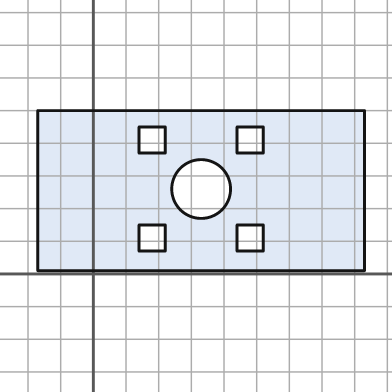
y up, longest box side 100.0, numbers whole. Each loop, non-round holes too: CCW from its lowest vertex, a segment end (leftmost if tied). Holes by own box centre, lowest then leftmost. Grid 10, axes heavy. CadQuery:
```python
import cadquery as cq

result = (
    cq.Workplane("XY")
    .moveTo(-17.0, 1.0)
    .lineTo(83.0, 1.0)
    .lineTo(83.0, 50.0)
    .lineTo(-17.0, 50.0)
    .close()
    .moveTo(14.0, 7.0)
    .lineTo(22.0, 7.0)
    .lineTo(22.0, 15.0)
    .lineTo(14.0, 15.0)
    .close()
    .moveTo(44.0, 7.0)
    .lineTo(52.0, 7.0)
    .lineTo(52.0, 15.0)
    .lineTo(44.0, 15.0)
    .close()
    .moveTo(33.0, 26.0)
    .circle(9.0)
    .moveTo(14.0, 37.0)
    .lineTo(22.0, 37.0)
    .lineTo(22.0, 45.0)
    .lineTo(14.0, 45.0)
    .close()
    .moveTo(44.0, 37.0)
    .lineTo(52.0, 37.0)
    .lineTo(52.0, 45.0)
    .lineTo(44.0, 45.0)
    .close()
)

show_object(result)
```